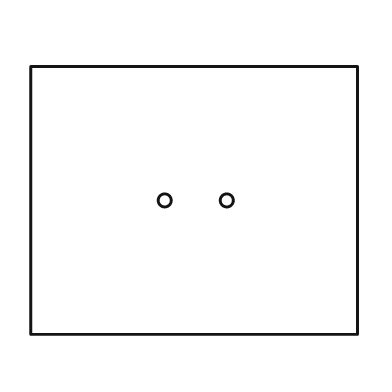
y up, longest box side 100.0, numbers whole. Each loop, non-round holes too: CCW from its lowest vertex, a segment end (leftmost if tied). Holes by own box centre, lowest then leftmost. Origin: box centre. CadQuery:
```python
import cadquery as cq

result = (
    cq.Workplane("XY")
    .moveTo(-50.0, -41.0)
    .lineTo(50.0, -41.0)
    .lineTo(50.0, 41.0)
    .lineTo(-50.0, 41.0)
    .close()
    .moveTo(-9.0, 0.0)
    .circle(2.0)
    .moveTo(10.0, 0.0)
    .circle(2.0)
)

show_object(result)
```